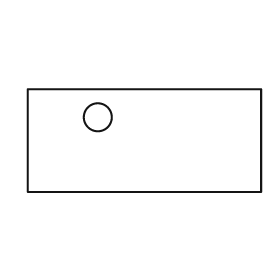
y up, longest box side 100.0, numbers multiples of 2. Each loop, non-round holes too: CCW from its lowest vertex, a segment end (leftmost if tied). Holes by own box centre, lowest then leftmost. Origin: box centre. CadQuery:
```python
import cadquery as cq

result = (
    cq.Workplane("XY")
    .moveTo(-50.0, -22.0)
    .lineTo(50.0, -22.0)
    .lineTo(50.0, 22.0)
    .lineTo(-50.0, 22.0)
    .close()
    .moveTo(-20.0, 10.0)
    .circle(6.0)
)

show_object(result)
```